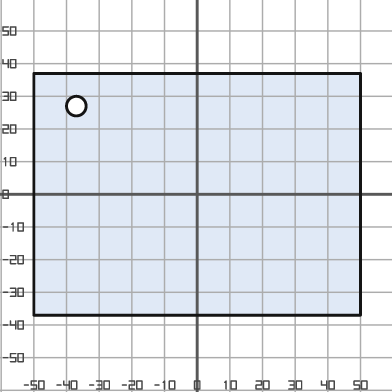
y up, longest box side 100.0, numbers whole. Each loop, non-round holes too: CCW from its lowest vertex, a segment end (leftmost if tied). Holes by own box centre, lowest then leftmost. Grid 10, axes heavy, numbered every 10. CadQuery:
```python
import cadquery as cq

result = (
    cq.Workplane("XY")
    .moveTo(-50.0, -37.0)
    .lineTo(50.0, -37.0)
    .lineTo(50.0, 37.0)
    .lineTo(-50.0, 37.0)
    .close()
    .moveTo(-37.0, 27.0)
    .circle(3.0)
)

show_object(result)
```